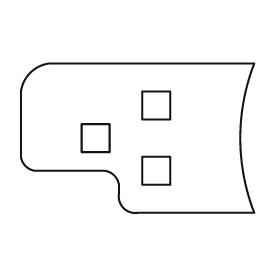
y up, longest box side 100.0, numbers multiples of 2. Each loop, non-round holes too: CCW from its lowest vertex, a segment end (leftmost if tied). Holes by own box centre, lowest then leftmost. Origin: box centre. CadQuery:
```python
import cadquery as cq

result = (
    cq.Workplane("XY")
    .moveTo(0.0, -32.0)
    .lineTo(50.0, -32.0)
    .threePointArc((44.0, 0.0), (50.0, 32.0))
    .lineTo(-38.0, 32.0)
    .threePointArc((-46.0, 28.0), (-50.0, 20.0))
    .lineTo(-50.0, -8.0)
    .threePointArc((-48.0, -12.0), (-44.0, -14.0))
    .lineTo(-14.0, -14.0)
    .threePointArc((-10.0, -16.0), (-8.0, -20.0))
    .lineTo(-8.0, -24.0)
    .threePointArc((-6.0, -30.0), (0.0, -32.0))
    .close()
    .moveTo(2.0, -20.0)
    .lineTo(14.0, -20.0)
    .lineTo(14.0, -8.0)
    .lineTo(2.0, -8.0)
    .close()
    .moveTo(-24.0, -6.0)
    .lineTo(-12.0, -6.0)
    .lineTo(-12.0, 6.0)
    .lineTo(-24.0, 6.0)
    .close()
    .moveTo(2.0, 8.0)
    .lineTo(14.0, 8.0)
    .lineTo(14.0, 20.0)
    .lineTo(2.0, 20.0)
    .close()
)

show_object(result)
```